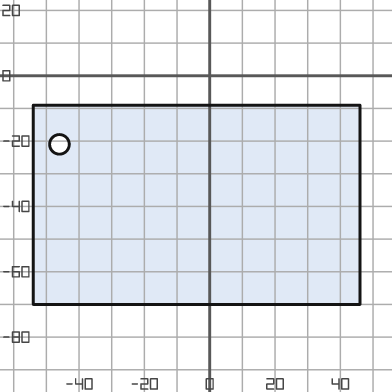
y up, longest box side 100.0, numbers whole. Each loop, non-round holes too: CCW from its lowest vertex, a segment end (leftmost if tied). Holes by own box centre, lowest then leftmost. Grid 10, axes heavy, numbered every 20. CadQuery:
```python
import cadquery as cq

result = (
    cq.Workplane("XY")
    .moveTo(-54.0, -70.0)
    .lineTo(46.0, -70.0)
    .lineTo(46.0, -9.0)
    .lineTo(-54.0, -9.0)
    .close()
    .moveTo(-46.0, -21.0)
    .circle(3.0)
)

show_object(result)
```